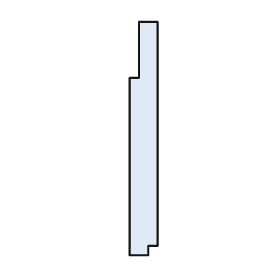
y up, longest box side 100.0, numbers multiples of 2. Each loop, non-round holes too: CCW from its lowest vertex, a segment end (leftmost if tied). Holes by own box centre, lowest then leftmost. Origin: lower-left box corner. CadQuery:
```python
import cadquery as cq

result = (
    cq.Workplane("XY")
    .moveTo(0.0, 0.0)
    .lineTo(8.0, 0.0)
    .lineTo(8.0, 4.0)
    .lineTo(12.0, 4.0)
    .lineTo(12.0, 100.0)
    .lineTo(4.0, 100.0)
    .lineTo(4.0, 76.0)
    .lineTo(0.0, 76.0)
    .close()
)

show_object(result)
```